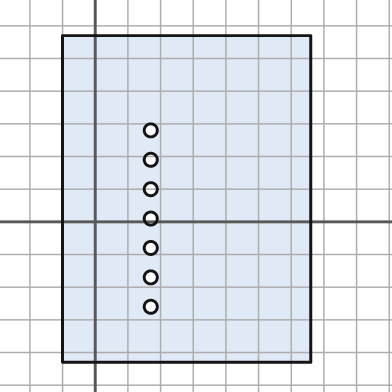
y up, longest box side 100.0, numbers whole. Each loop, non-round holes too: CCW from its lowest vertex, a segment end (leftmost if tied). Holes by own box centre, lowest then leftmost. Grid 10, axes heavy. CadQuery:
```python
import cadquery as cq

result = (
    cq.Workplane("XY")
    .moveTo(-10.0, -43.0)
    .lineTo(66.0, -43.0)
    .lineTo(66.0, 57.0)
    .lineTo(-10.0, 57.0)
    .close()
    .moveTo(17.0, -26.0)
    .circle(2.0)
    .moveTo(17.0, -17.0)
    .circle(2.0)
    .moveTo(17.0, -8.0)
    .circle(2.0)
    .moveTo(17.0, 1.0)
    .circle(2.0)
    .moveTo(17.0, 10.0)
    .circle(2.0)
    .moveTo(17.0, 19.0)
    .circle(2.0)
    .moveTo(17.0, 28.0)
    .circle(2.0)
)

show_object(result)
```